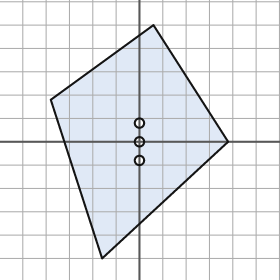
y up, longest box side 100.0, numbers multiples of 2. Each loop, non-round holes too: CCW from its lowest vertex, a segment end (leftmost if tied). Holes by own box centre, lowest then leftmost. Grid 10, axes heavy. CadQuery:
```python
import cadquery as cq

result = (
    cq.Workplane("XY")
    .moveTo(-16.0, -50.0)
    .lineTo(38.0, 0.0)
    .lineTo(6.0, 50.0)
    .lineTo(-38.0, 18.0)
    .close()
    .moveTo(0.0, -8.0)
    .circle(2.0)
    .moveTo(0.0, 0.0)
    .circle(2.0)
    .moveTo(0.0, 8.0)
    .circle(2.0)
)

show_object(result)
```